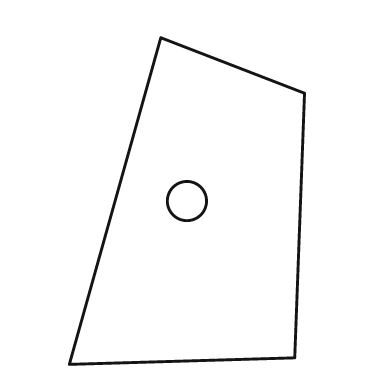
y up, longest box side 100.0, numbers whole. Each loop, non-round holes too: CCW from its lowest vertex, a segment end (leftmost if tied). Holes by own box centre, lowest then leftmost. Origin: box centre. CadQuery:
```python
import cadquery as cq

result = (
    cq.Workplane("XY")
    .moveTo(-36.0, -50.0)
    .lineTo(33.0, -48.0)
    .lineTo(36.0, 33.0)
    .lineTo(-8.0, 50.0)
    .close()
    .moveTo(0.0, 0.0)
    .circle(6.0)
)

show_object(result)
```